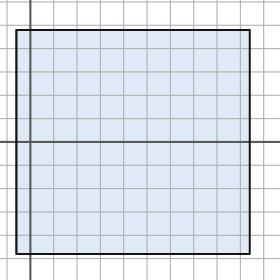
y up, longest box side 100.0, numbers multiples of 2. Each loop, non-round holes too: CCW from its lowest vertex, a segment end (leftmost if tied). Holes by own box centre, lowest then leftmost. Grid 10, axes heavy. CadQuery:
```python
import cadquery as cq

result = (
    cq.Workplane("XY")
    .moveTo(-6.0, -48.0)
    .lineTo(94.0, -48.0)
    .lineTo(94.0, 48.0)
    .lineTo(-6.0, 48.0)
    .close()
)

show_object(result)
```